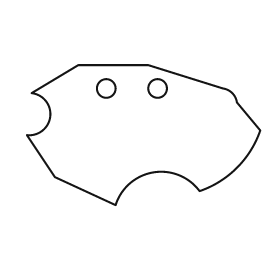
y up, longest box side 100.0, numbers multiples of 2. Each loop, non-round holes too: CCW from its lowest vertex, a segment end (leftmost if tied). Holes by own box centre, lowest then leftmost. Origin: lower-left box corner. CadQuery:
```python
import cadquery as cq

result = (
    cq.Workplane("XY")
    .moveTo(38.0, 0.0)
    .threePointArc((54.0, 14.0), (74.0, 6.0))
    .threePointArc((90.0, 16.0), (100.0, 32.0))
    .lineTo(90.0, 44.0)
    .threePointArc((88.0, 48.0), (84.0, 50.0))
    .lineTo(52.0, 60.0)
    .lineTo(22.0, 60.0)
    .lineTo(2.0, 48.0)
    .threePointArc((10.0, 38.0), (0.0, 30.0))
    .lineTo(12.0, 12.0)
    .close()
    .moveTo(34.0, 50.0)
    .circle(4.0)
    .moveTo(56.0, 50.0)
    .circle(4.0)
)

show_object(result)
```